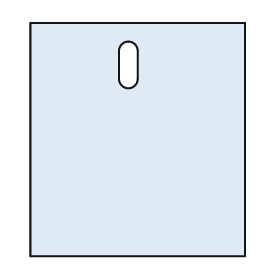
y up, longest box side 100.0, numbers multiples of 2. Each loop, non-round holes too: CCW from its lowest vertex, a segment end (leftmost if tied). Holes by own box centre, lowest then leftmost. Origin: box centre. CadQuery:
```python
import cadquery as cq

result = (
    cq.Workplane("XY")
    .moveTo(-46.0, -50.0)
    .lineTo(46.0, -50.0)
    .lineTo(46.0, 50.0)
    .lineTo(-46.0, 50.0)
    .close()
    .moveTo(-8.0, 26.0)
    .threePointArc((-4.0, 22.0), (0.0, 26.0))
    .lineTo(0.0, 38.0)
    .threePointArc((-4.0, 42.0), (-8.0, 38.0))
    .close()
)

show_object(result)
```